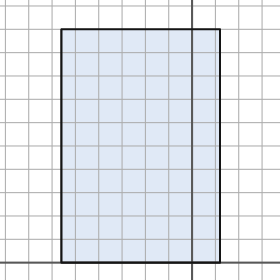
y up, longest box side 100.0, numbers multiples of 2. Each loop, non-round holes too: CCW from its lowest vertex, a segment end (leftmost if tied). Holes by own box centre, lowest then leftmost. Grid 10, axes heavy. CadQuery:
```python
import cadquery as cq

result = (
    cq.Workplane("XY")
    .moveTo(-56.0, 0.0)
    .lineTo(12.0, 0.0)
    .lineTo(12.0, 100.0)
    .lineTo(-56.0, 100.0)
    .close()
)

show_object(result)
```